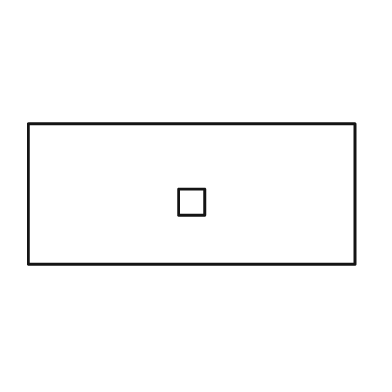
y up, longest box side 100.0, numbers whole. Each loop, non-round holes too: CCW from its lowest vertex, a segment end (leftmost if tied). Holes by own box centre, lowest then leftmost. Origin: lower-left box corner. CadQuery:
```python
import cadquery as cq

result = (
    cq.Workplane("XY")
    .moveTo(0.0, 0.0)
    .lineTo(100.0, 0.0)
    .lineTo(100.0, 43.0)
    .lineTo(0.0, 43.0)
    .close()
    .moveTo(46.0, 15.0)
    .lineTo(54.0, 15.0)
    .lineTo(54.0, 23.0)
    .lineTo(46.0, 23.0)
    .close()
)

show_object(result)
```